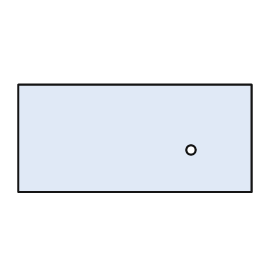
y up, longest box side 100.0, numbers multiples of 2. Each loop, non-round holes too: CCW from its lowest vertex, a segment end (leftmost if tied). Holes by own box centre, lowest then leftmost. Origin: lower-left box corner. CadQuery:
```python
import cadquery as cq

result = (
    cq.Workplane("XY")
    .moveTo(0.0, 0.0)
    .lineTo(100.0, 0.0)
    .lineTo(100.0, 46.0)
    .lineTo(0.0, 46.0)
    .close()
    .moveTo(74.0, 18.0)
    .circle(2.0)
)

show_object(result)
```